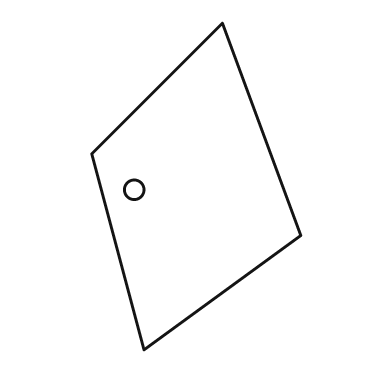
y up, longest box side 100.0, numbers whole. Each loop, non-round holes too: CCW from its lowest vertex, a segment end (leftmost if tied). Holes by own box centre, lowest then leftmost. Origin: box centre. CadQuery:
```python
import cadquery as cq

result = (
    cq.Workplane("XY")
    .moveTo(-16.0, -50.0)
    .lineTo(32.0, -15.0)
    .lineTo(8.0, 50.0)
    .lineTo(-32.0, 10.0)
    .close()
    .moveTo(-19.0, -1.0)
    .circle(3.0)
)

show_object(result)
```